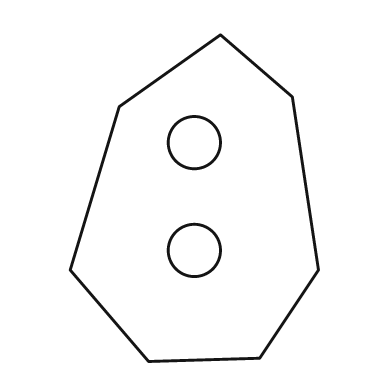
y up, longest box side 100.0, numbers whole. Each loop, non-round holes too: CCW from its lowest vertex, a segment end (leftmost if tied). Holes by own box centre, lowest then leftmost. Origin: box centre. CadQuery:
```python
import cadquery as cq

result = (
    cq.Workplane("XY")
    .moveTo(-14.0, -50.0)
    .lineTo(20.0, -49.0)
    .lineTo(38.0, -22.0)
    .lineTo(30.0, 31.0)
    .lineTo(8.0, 50.0)
    .lineTo(-23.0, 28.0)
    .lineTo(-38.0, -22.0)
    .close()
    .moveTo(0.0, -16.0)
    .circle(8.0)
    .moveTo(0.0, 17.0)
    .circle(8.0)
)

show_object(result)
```